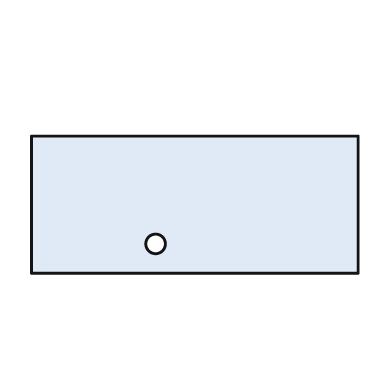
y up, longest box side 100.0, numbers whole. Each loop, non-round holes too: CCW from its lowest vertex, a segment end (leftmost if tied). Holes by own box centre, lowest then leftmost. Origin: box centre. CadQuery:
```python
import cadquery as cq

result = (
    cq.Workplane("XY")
    .moveTo(-50.0, -21.0)
    .lineTo(50.0, -21.0)
    .lineTo(50.0, 21.0)
    .lineTo(-50.0, 21.0)
    .close()
    .moveTo(-12.0, -12.0)
    .circle(3.0)
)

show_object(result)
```